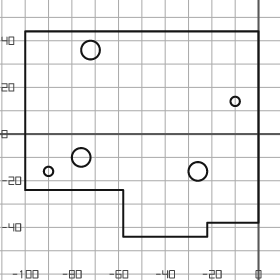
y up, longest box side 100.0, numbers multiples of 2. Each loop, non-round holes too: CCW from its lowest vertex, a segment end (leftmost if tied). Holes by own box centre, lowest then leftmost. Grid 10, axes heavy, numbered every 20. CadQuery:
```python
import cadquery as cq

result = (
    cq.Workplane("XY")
    .moveTo(-58.0, -44.0)
    .lineTo(-22.0, -44.0)
    .lineTo(-22.0, -38.0)
    .lineTo(0.0, -38.0)
    .lineTo(0.0, 44.0)
    .lineTo(-100.0, 44.0)
    .lineTo(-100.0, -24.0)
    .lineTo(-58.0, -24.0)
    .close()
    .moveTo(-90.0, -16.0)
    .circle(2.0)
    .moveTo(-26.0, -16.0)
    .circle(4.0)
    .moveTo(-76.0, -10.0)
    .circle(4.0)
    .moveTo(-10.0, 14.0)
    .circle(2.0)
    .moveTo(-72.0, 36.0)
    .circle(4.0)
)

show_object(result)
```